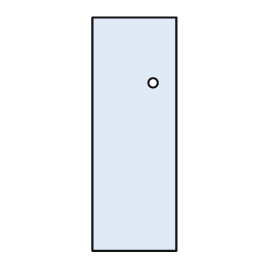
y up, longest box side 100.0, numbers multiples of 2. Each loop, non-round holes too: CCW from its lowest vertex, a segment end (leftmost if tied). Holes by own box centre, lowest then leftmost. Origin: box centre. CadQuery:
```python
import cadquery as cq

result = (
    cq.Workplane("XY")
    .moveTo(-18.0, -50.0)
    .lineTo(18.0, -50.0)
    .lineTo(18.0, 50.0)
    .lineTo(-18.0, 50.0)
    .close()
    .moveTo(8.0, 22.0)
    .circle(2.0)
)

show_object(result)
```